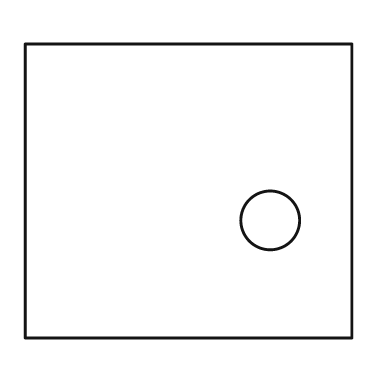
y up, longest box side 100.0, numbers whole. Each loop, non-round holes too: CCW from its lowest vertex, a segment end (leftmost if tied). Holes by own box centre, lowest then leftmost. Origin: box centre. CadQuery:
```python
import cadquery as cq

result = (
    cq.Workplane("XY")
    .moveTo(-50.0, -45.0)
    .lineTo(50.0, -45.0)
    .lineTo(50.0, 45.0)
    .lineTo(-50.0, 45.0)
    .close()
    .moveTo(25.0, -9.0)
    .circle(9.0)
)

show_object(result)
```